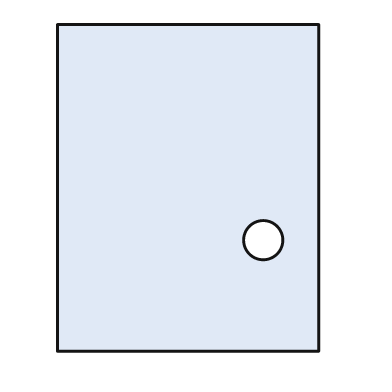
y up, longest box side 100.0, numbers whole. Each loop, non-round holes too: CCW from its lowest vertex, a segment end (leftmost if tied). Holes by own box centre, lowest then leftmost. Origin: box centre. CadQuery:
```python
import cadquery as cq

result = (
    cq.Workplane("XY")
    .moveTo(-40.0, -50.0)
    .lineTo(40.0, -50.0)
    .lineTo(40.0, 50.0)
    .lineTo(-40.0, 50.0)
    .close()
    .moveTo(23.0, -16.0)
    .circle(6.0)
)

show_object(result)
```